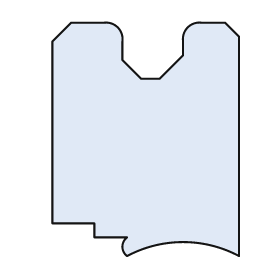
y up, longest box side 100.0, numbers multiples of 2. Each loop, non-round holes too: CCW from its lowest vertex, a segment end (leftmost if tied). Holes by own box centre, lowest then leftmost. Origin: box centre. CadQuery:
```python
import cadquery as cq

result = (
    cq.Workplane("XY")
    .moveTo(-8.0, -50.0)
    .threePointArc((16.0, -44.0), (40.0, -50.0))
    .lineTo(40.0, 44.0)
    .lineTo(34.0, 50.0)
    .lineTo(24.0, 50.0)
    .threePointArc((18.0, 48.0), (16.0, 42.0))
    .lineTo(16.0, 36.0)
    .lineTo(6.0, 26.0)
    .lineTo(-2.0, 26.0)
    .lineTo(-10.0, 34.0)
    .lineTo(-10.0, 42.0)
    .threePointArc((-12.0, 48.0), (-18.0, 50.0))
    .lineTo(-32.0, 50.0)
    .lineTo(-40.0, 42.0)
    .lineTo(-40.0, -36.0)
    .lineTo(-22.0, -36.0)
    .lineTo(-22.0, -42.0)
    .lineTo(-8.0, -42.0)
    .threePointArc((-10.0, -46.0), (-8.0, -50.0))
    .close()
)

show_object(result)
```